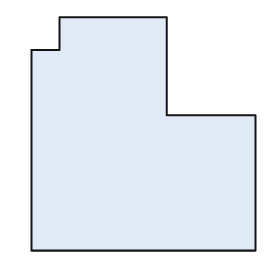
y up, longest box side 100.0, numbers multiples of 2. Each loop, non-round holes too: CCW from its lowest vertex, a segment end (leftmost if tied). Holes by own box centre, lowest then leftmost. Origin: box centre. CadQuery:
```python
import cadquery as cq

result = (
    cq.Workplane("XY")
    .moveTo(-48.0, -50.0)
    .lineTo(48.0, -50.0)
    .lineTo(48.0, 8.0)
    .lineTo(10.0, 8.0)
    .lineTo(10.0, 50.0)
    .lineTo(-36.0, 50.0)
    .lineTo(-36.0, 36.0)
    .lineTo(-48.0, 36.0)
    .close()
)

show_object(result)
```